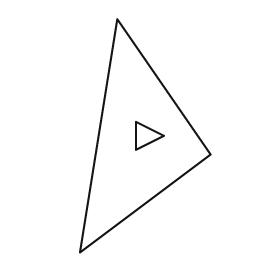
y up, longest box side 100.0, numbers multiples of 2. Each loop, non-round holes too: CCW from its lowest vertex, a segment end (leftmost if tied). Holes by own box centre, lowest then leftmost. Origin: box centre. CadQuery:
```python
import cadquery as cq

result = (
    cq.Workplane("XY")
    .moveTo(-28.0, -50.0)
    .lineTo(28.0, -8.0)
    .lineTo(-12.0, 50.0)
    .close()
    .moveTo(-4.0, -6.0)
    .lineTo(8.0, 0.0)
    .lineTo(-4.0, 6.0)
    .close()
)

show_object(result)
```